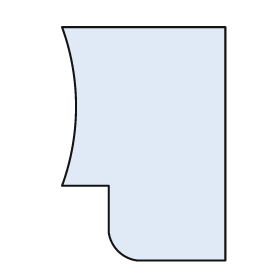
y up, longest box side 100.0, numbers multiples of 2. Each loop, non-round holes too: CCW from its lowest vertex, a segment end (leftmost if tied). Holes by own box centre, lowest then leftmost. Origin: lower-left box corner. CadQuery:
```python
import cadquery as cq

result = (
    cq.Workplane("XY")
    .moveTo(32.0, 0.0)
    .lineTo(70.0, 0.0)
    .lineTo(70.0, 100.0)
    .lineTo(0.0, 100.0)
    .threePointArc((6.0, 66.0), (0.0, 32.0))
    .lineTo(20.0, 32.0)
    .lineTo(20.0, 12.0)
    .threePointArc((24.0, 4.0), (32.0, 0.0))
    .close()
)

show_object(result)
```